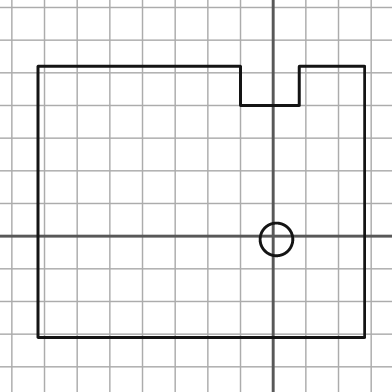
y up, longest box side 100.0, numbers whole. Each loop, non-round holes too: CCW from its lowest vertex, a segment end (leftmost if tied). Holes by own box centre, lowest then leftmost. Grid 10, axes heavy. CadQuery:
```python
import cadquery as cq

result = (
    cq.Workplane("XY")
    .moveTo(-72.0, -31.0)
    .lineTo(28.0, -31.0)
    .lineTo(28.0, 52.0)
    .lineTo(8.0, 52.0)
    .lineTo(8.0, 40.0)
    .lineTo(-10.0, 40.0)
    .lineTo(-10.0, 52.0)
    .lineTo(-72.0, 52.0)
    .close()
    .moveTo(1.0, -1.0)
    .circle(5.0)
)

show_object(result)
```